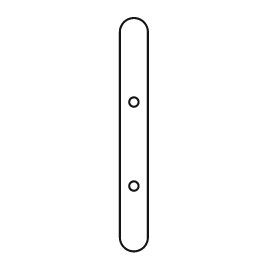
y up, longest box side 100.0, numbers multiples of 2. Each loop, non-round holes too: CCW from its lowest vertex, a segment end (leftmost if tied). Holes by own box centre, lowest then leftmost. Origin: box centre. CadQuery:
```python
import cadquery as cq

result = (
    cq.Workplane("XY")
    .moveTo(-6.0, -44.0)
    .threePointArc((0.0, -50.0), (6.0, -44.0))
    .lineTo(6.0, 44.0)
    .threePointArc((0.0, 50.0), (-6.0, 44.0))
    .close()
    .moveTo(0.0, -22.0)
    .circle(2.0)
    .moveTo(0.0, 14.0)
    .circle(2.0)
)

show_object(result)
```